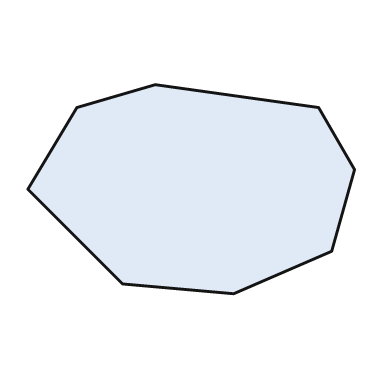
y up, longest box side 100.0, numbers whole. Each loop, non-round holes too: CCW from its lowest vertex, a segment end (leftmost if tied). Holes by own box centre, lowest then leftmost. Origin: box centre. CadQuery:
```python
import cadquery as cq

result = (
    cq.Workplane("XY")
    .moveTo(13.0, -32.0)
    .lineTo(43.0, -19.0)
    .lineTo(50.0, 6.0)
    .lineTo(39.0, 25.0)
    .lineTo(-11.0, 32.0)
    .lineTo(-35.0, 25.0)
    .lineTo(-50.0, 0.0)
    .lineTo(-21.0, -29.0)
    .close()
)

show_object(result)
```